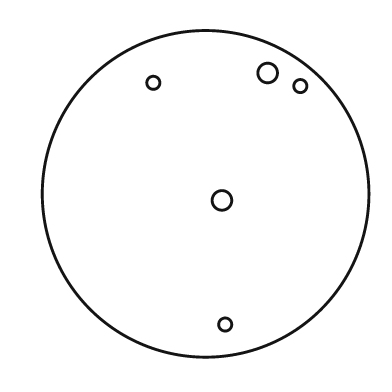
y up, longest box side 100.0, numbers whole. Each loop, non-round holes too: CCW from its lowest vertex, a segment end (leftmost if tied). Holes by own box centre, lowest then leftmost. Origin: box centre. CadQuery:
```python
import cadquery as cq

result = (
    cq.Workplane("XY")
    .moveTo(0.0, 0.0)
    .circle(50.0)
    .moveTo(6.0, -40.0)
    .circle(2.0)
    .moveTo(5.0, -2.0)
    .circle(3.0)
    .moveTo(29.0, 33.0)
    .circle(2.0)
    .moveTo(-16.0, 34.0)
    .circle(2.0)
    .moveTo(19.0, 37.0)
    .circle(3.0)
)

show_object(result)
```